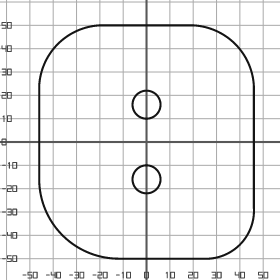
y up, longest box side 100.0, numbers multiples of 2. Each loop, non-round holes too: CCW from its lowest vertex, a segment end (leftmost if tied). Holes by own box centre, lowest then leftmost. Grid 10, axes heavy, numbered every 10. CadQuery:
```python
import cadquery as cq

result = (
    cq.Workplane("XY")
    .moveTo(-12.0, -50.0)
    .lineTo(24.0, -50.0)
    .threePointArc((40.0, -44.0), (46.0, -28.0))
    .lineTo(46.0, 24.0)
    .threePointArc((38.0, 42.0), (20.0, 50.0))
    .lineTo(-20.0, 50.0)
    .threePointArc((-38.0, 42.0), (-46.0, 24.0))
    .lineTo(-46.0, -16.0)
    .threePointArc((-36.0, -40.0), (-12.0, -50.0))
    .close()
    .moveTo(0.0, -16.0)
    .circle(6.0)
    .moveTo(0.0, 16.0)
    .circle(6.0)
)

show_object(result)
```